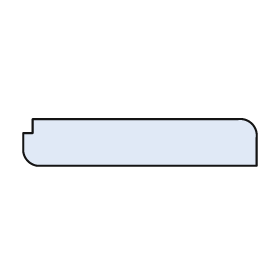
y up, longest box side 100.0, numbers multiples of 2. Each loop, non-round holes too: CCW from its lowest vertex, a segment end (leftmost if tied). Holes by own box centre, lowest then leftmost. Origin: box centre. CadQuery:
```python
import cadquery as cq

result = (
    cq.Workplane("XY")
    .moveTo(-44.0, -10.0)
    .lineTo(50.0, -10.0)
    .lineTo(50.0, 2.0)
    .threePointArc((48.0, 8.0), (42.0, 10.0))
    .lineTo(-46.0, 10.0)
    .lineTo(-46.0, 4.0)
    .lineTo(-50.0, 4.0)
    .lineTo(-50.0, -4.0)
    .threePointArc((-48.0, -8.0), (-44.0, -10.0))
    .close()
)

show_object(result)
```